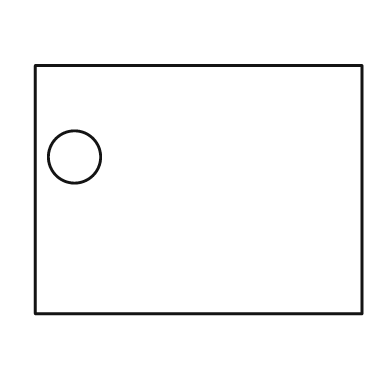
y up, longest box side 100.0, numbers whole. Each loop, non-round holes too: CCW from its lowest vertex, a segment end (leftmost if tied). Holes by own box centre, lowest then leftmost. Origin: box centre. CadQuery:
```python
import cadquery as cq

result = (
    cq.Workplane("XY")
    .moveTo(-50.0, -38.0)
    .lineTo(50.0, -38.0)
    .lineTo(50.0, 38.0)
    .lineTo(-50.0, 38.0)
    .close()
    .moveTo(-38.0, 10.0)
    .circle(8.0)
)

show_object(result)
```